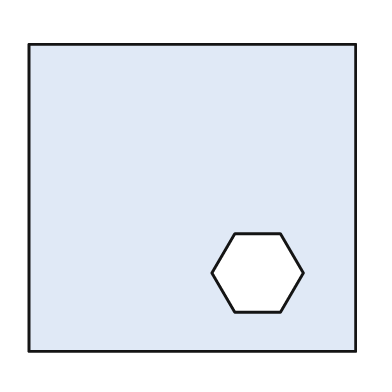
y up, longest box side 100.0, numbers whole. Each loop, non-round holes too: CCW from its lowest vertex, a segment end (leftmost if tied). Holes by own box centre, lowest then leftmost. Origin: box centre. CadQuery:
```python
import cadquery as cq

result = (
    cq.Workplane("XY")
    .moveTo(-50.0, -47.0)
    .lineTo(50.0, -47.0)
    .lineTo(50.0, 47.0)
    .lineTo(-50.0, 47.0)
    .close()
    .moveTo(13.0, -35.0)
    .lineTo(27.0, -35.0)
    .lineTo(34.0, -23.0)
    .lineTo(27.0, -11.0)
    .lineTo(13.0, -11.0)
    .lineTo(6.0, -23.0)
    .close()
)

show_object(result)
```